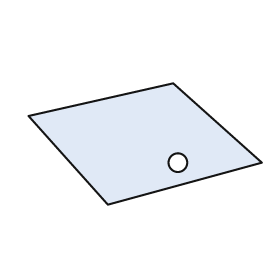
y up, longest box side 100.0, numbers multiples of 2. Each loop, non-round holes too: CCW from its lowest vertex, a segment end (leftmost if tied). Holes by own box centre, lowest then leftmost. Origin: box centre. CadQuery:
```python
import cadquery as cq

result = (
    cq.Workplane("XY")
    .moveTo(-16.0, -26.0)
    .lineTo(50.0, -8.0)
    .lineTo(12.0, 26.0)
    .lineTo(-50.0, 12.0)
    .close()
    .moveTo(14.0, -8.0)
    .circle(4.0)
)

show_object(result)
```